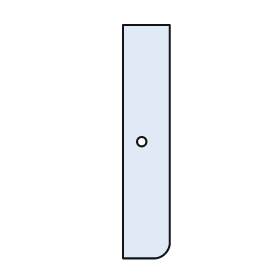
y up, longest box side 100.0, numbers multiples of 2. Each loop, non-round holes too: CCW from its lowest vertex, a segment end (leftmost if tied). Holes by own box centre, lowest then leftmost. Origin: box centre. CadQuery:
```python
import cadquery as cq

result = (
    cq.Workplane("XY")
    .moveTo(-10.0, -50.0)
    .lineTo(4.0, -50.0)
    .threePointArc((8.0, -48.0), (10.0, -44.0))
    .lineTo(10.0, 50.0)
    .lineTo(-10.0, 50.0)
    .close()
    .moveTo(-2.0, 0.0)
    .circle(2.0)
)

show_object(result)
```